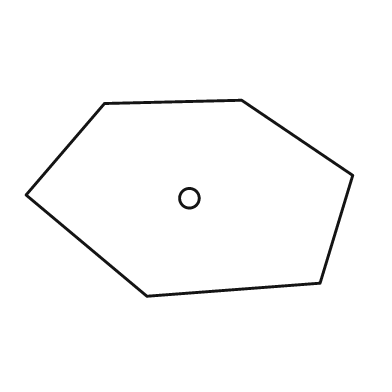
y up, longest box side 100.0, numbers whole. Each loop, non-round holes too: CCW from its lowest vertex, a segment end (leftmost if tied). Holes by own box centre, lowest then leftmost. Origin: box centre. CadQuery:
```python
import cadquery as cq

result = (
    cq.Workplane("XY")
    .moveTo(-13.0, -30.0)
    .lineTo(40.0, -26.0)
    .lineTo(50.0, 7.0)
    .lineTo(16.0, 30.0)
    .lineTo(-26.0, 29.0)
    .lineTo(-50.0, 1.0)
    .close()
    .moveTo(0.0, 0.0)
    .circle(3.0)
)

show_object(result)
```